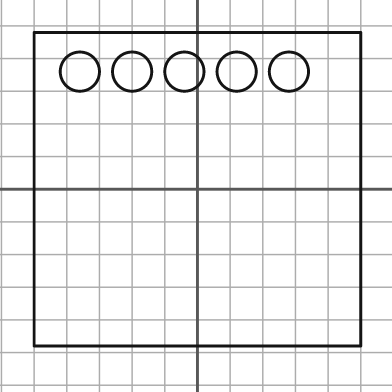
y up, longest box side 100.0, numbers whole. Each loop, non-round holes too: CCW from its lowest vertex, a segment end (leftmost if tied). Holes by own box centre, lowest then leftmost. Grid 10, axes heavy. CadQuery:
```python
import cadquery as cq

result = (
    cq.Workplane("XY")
    .moveTo(-50.0, -48.0)
    .lineTo(50.0, -48.0)
    .lineTo(50.0, 48.0)
    .lineTo(-50.0, 48.0)
    .close()
    .moveTo(-36.0, 36.0)
    .circle(6.0)
    .moveTo(-20.0, 36.0)
    .circle(6.0)
    .moveTo(-4.0, 36.0)
    .circle(6.0)
    .moveTo(12.0, 36.0)
    .circle(6.0)
    .moveTo(28.0, 36.0)
    .circle(6.0)
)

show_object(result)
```